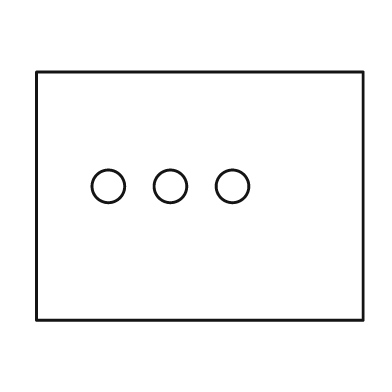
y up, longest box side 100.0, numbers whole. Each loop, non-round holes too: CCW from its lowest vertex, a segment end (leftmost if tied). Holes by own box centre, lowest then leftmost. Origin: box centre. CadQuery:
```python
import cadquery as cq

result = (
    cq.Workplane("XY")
    .moveTo(-50.0, -38.0)
    .lineTo(50.0, -38.0)
    .lineTo(50.0, 38.0)
    .lineTo(-50.0, 38.0)
    .close()
    .moveTo(-28.0, 3.0)
    .circle(5.0)
    .moveTo(-9.0, 3.0)
    .circle(5.0)
    .moveTo(10.0, 3.0)
    .circle(5.0)
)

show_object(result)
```